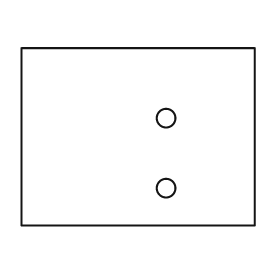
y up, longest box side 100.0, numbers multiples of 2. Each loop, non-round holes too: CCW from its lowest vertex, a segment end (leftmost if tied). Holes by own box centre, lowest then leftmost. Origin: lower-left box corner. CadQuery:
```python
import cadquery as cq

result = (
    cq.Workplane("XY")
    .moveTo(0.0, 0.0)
    .lineTo(100.0, 0.0)
    .lineTo(100.0, 76.0)
    .lineTo(0.0, 76.0)
    .close()
    .moveTo(62.0, 16.0)
    .circle(4.0)
    .moveTo(62.0, 46.0)
    .circle(4.0)
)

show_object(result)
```